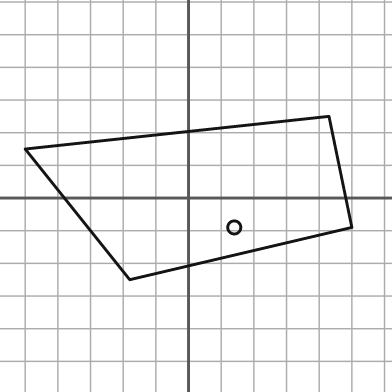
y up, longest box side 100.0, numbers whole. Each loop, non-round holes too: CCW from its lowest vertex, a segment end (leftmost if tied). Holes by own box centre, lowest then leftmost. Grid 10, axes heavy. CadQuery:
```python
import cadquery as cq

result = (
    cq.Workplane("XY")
    .moveTo(-18.0, -25.0)
    .lineTo(50.0, -9.0)
    .lineTo(43.0, 25.0)
    .lineTo(-50.0, 15.0)
    .close()
    .moveTo(14.0, -9.0)
    .circle(2.0)
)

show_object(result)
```